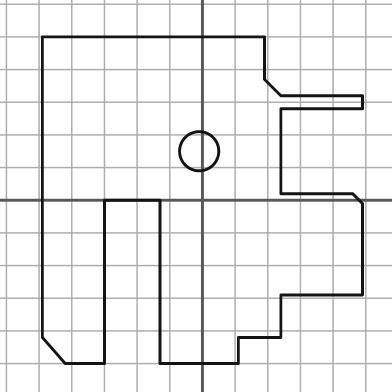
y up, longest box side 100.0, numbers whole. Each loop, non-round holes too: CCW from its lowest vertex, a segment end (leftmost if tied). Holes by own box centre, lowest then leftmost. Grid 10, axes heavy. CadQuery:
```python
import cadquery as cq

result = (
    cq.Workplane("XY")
    .moveTo(-42.0, -50.0)
    .lineTo(-30.0, -50.0)
    .lineTo(-30.0, 0.0)
    .lineTo(-13.0, 0.0)
    .lineTo(-13.0, -50.0)
    .lineTo(11.0, -50.0)
    .lineTo(11.0, -42.0)
    .lineTo(24.0, -42.0)
    .lineTo(24.0, -29.0)
    .lineTo(49.0, -29.0)
    .lineTo(49.0, -1.0)
    .lineTo(46.0, 2.0)
    .lineTo(24.0, 2.0)
    .lineTo(24.0, 28.0)
    .lineTo(49.0, 28.0)
    .lineTo(49.0, 32.0)
    .lineTo(24.0, 32.0)
    .lineTo(19.0, 37.0)
    .lineTo(19.0, 50.0)
    .lineTo(-49.0, 50.0)
    .lineTo(-49.0, -42.0)
    .close()
    .moveTo(-1.0, 15.0)
    .circle(6.0)
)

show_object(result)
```